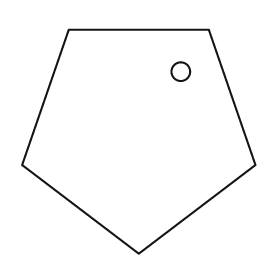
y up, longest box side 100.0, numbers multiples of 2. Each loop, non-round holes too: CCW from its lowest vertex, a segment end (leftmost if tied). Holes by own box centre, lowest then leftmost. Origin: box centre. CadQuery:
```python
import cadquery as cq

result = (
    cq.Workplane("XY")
    .moveTo(0.0, -48.0)
    .lineTo(50.0, -10.0)
    .lineTo(30.0, 48.0)
    .lineTo(-30.0, 48.0)
    .lineTo(-50.0, -10.0)
    .close()
    .moveTo(18.0, 30.0)
    .circle(4.0)
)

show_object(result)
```